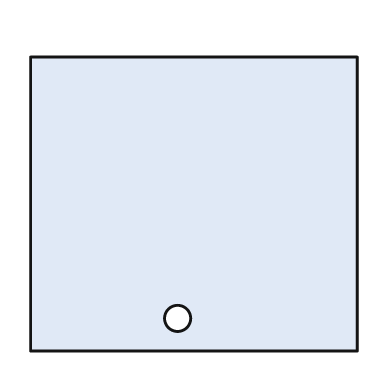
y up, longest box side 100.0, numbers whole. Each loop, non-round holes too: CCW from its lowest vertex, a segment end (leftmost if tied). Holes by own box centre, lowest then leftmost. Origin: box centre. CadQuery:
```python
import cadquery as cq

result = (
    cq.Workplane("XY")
    .moveTo(-50.0, -45.0)
    .lineTo(50.0, -45.0)
    .lineTo(50.0, 45.0)
    .lineTo(-50.0, 45.0)
    .close()
    .moveTo(-5.0, -35.0)
    .circle(4.0)
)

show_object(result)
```